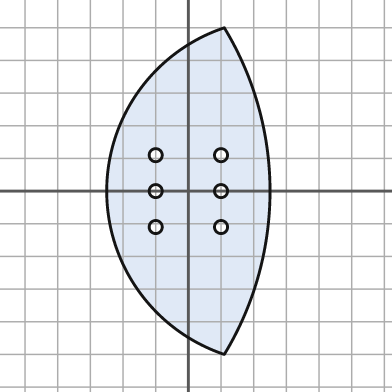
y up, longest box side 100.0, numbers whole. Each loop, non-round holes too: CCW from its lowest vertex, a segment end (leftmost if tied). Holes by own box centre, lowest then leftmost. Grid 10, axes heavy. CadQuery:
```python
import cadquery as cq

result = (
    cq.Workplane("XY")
    .moveTo(11.0, -50.0)
    .threePointArc((25.0, 0.0), (11.0, 50.0))
    .threePointArc((-25.0, 0.0), (11.0, -50.0))
    .close()
    .moveTo(-10.0, -11.0)
    .circle(2.0)
    .moveTo(10.0, -11.0)
    .circle(2.0)
    .moveTo(-10.0, 0.0)
    .circle(2.0)
    .moveTo(10.0, 0.0)
    .circle(2.0)
    .moveTo(-10.0, 11.0)
    .circle(2.0)
    .moveTo(10.0, 11.0)
    .circle(2.0)
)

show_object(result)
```